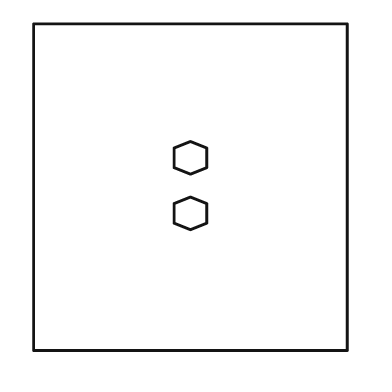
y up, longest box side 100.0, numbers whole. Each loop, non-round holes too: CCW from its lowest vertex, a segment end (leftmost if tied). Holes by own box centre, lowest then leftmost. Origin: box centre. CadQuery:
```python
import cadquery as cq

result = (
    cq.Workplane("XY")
    .moveTo(-48.0, -50.0)
    .lineTo(48.0, -50.0)
    .lineTo(48.0, 50.0)
    .lineTo(-48.0, 50.0)
    .close()
    .moveTo(0.0, -13.0)
    .lineTo(5.0, -11.0)
    .lineTo(5.0, -5.0)
    .lineTo(0.0, -3.0)
    .lineTo(-5.0, -5.0)
    .lineTo(-5.0, -11.0)
    .close()
    .moveTo(0.0, 4.0)
    .lineTo(5.0, 6.0)
    .lineTo(5.0, 12.0)
    .lineTo(0.0, 14.0)
    .lineTo(-5.0, 12.0)
    .lineTo(-5.0, 6.0)
    .close()
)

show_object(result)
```